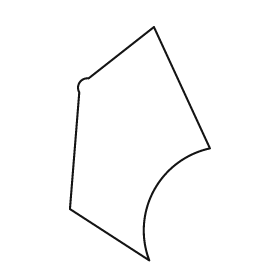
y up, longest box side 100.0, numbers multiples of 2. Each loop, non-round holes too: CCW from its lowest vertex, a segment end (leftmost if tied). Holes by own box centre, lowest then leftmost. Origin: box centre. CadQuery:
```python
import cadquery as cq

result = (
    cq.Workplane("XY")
    .moveTo(4.0, -50.0)
    .threePointArc((6.0, -20.0), (30.0, -2.0))
    .lineTo(6.0, 50.0)
    .lineTo(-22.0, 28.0)
    .threePointArc((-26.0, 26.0), (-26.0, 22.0))
    .lineTo(-30.0, -28.0)
    .close()
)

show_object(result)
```